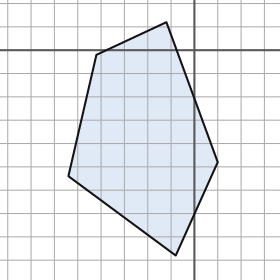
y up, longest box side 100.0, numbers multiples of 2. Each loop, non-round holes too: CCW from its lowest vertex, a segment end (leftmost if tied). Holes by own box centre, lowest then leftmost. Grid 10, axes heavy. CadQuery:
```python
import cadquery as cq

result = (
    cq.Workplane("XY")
    .moveTo(-8.0, -88.0)
    .lineTo(10.0, -48.0)
    .lineTo(-12.0, 12.0)
    .lineTo(-42.0, -2.0)
    .lineTo(-54.0, -54.0)
    .close()
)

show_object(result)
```